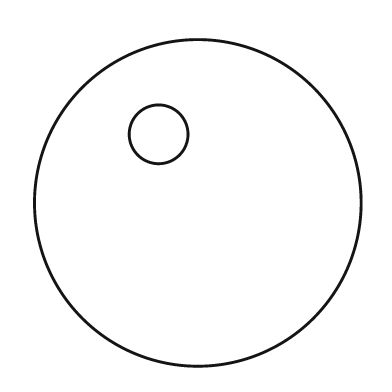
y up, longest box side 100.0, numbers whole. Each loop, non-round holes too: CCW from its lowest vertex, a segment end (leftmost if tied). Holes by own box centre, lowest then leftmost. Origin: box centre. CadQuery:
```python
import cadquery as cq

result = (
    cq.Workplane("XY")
    .moveTo(0.0, 0.0)
    .circle(50.0)
    .moveTo(-12.0, 21.0)
    .circle(9.0)
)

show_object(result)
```